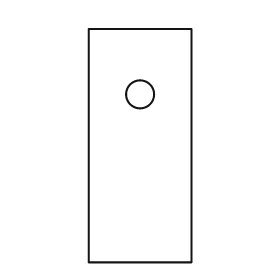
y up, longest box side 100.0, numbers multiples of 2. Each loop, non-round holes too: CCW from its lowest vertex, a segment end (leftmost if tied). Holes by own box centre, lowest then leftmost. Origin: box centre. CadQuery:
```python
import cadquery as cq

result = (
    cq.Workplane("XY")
    .moveTo(-22.0, -50.0)
    .lineTo(22.0, -50.0)
    .lineTo(22.0, 50.0)
    .lineTo(-22.0, 50.0)
    .close()
    .moveTo(0.0, 22.0)
    .circle(6.0)
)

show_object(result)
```